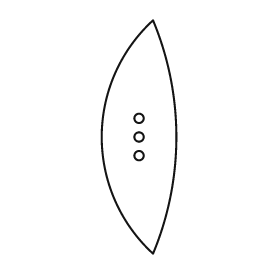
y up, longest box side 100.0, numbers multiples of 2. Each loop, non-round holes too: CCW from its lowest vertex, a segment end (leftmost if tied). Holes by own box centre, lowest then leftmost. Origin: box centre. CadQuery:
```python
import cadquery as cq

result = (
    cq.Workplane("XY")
    .moveTo(6.0, -50.0)
    .threePointArc((16.0, 0.0), (6.0, 50.0))
    .threePointArc((-16.0, 0.0), (6.0, -50.0))
    .close()
    .moveTo(0.0, -8.0)
    .circle(2.0)
    .moveTo(0.0, 0.0)
    .circle(2.0)
    .moveTo(0.0, 8.0)
    .circle(2.0)
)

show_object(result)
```